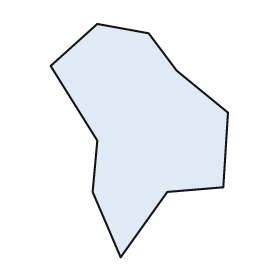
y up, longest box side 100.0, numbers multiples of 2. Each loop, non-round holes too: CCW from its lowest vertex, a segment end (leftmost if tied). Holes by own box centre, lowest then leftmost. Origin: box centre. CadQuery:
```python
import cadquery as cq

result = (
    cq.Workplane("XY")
    .moveTo(-8.0, -50.0)
    .lineTo(12.0, -22.0)
    .lineTo(36.0, -20.0)
    .lineTo(38.0, 12.0)
    .lineTo(16.0, 30.0)
    .lineTo(4.0, 46.0)
    .lineTo(-18.0, 50.0)
    .lineTo(-38.0, 32.0)
    .lineTo(-18.0, 0.0)
    .lineTo(-20.0, -22.0)
    .close()
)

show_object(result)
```